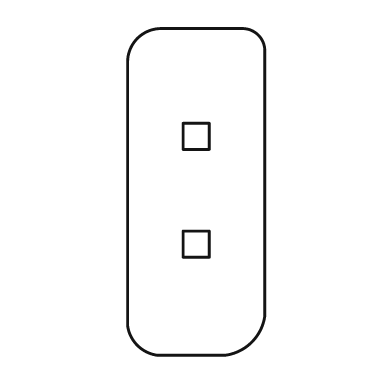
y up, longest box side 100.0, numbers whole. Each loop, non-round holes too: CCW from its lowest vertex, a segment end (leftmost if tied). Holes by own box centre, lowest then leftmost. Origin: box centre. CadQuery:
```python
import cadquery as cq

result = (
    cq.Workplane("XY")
    .moveTo(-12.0, -50.0)
    .lineTo(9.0, -50.0)
    .threePointArc((17.0, -46.0), (21.0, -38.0))
    .lineTo(21.0, 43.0)
    .threePointArc((19.0, 48.0), (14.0, 50.0))
    .lineTo(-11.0, 50.0)
    .threePointArc((-18.0, 47.0), (-21.0, 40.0))
    .lineTo(-21.0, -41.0)
    .threePointArc((-18.0, -47.0), (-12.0, -50.0))
    .close()
    .moveTo(-4.0, -20.0)
    .lineTo(4.0, -20.0)
    .lineTo(4.0, -12.0)
    .lineTo(-4.0, -12.0)
    .close()
    .moveTo(-4.0, 13.0)
    .lineTo(4.0, 13.0)
    .lineTo(4.0, 21.0)
    .lineTo(-4.0, 21.0)
    .close()
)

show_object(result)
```